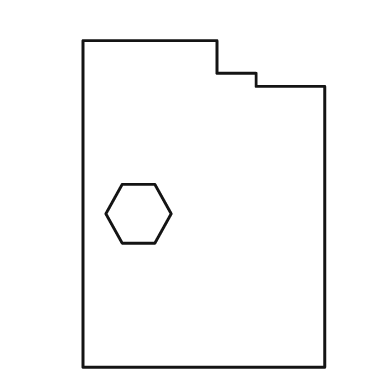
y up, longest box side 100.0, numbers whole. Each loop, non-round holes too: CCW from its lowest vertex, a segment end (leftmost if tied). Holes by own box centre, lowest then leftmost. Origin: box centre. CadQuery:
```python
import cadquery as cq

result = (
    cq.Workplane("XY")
    .moveTo(-37.0, -50.0)
    .lineTo(37.0, -50.0)
    .lineTo(37.0, 36.0)
    .lineTo(16.0, 36.0)
    .lineTo(16.0, 40.0)
    .lineTo(4.0, 40.0)
    .lineTo(4.0, 50.0)
    .lineTo(-37.0, 50.0)
    .close()
    .moveTo(-25.0, -12.0)
    .lineTo(-15.0, -12.0)
    .lineTo(-10.0, -3.0)
    .lineTo(-15.0, 6.0)
    .lineTo(-25.0, 6.0)
    .lineTo(-30.0, -3.0)
    .close()
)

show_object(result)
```